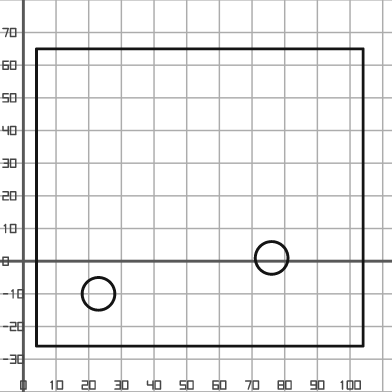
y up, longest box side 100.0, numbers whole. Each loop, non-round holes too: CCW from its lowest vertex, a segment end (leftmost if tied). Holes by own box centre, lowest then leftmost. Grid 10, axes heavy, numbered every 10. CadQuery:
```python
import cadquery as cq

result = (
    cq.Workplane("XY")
    .moveTo(4.0, -26.0)
    .lineTo(104.0, -26.0)
    .lineTo(104.0, 65.0)
    .lineTo(4.0, 65.0)
    .close()
    .moveTo(23.0, -10.0)
    .circle(5.0)
    .moveTo(76.0, 1.0)
    .circle(5.0)
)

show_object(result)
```